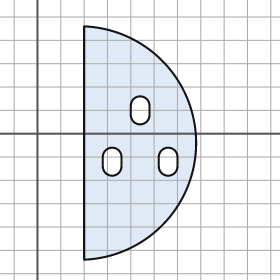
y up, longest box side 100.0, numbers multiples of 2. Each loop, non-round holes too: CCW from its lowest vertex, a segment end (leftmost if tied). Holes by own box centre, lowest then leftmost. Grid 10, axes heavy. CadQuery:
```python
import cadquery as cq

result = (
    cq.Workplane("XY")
    .moveTo(20.0, -54.0)
    .threePointArc((68.0, -4.0), (20.0, 46.0))
    .close()
    .moveTo(28.0, -14.0)
    .threePointArc((32.0, -18.0), (36.0, -14.0))
    .lineTo(36.0, -10.0)
    .threePointArc((32.0, -6.0), (28.0, -10.0))
    .close()
    .moveTo(52.0, -14.0)
    .threePointArc((56.0, -18.0), (60.0, -14.0))
    .lineTo(60.0, -10.0)
    .threePointArc((56.0, -6.0), (52.0, -10.0))
    .close()
    .moveTo(40.0, 8.0)
    .threePointArc((44.0, 4.0), (48.0, 8.0))
    .lineTo(48.0, 12.0)
    .threePointArc((44.0, 16.0), (40.0, 12.0))
    .close()
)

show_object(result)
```